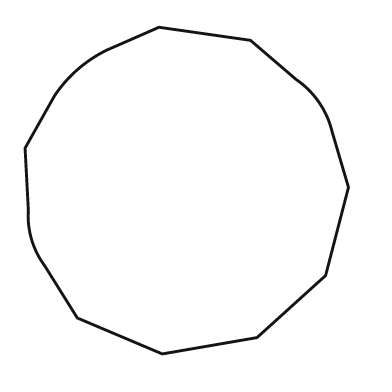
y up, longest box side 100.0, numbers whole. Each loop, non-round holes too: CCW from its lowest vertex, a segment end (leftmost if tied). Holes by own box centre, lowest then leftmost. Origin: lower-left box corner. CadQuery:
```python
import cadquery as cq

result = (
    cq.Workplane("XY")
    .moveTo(42.0, 0.0)
    .lineTo(71.0, 5.0)
    .lineTo(92.0, 24.0)
    .lineTo(99.0, 51.0)
    .lineTo(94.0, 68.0)
    .threePointArc((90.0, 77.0), (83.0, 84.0))
    .lineTo(69.0, 96.0)
    .lineTo(41.0, 100.0)
    .lineTo(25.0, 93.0)
    .threePointArc((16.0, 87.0), (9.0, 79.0))
    .lineTo(0.0, 63.0)
    .lineTo(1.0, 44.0)
    .threePointArc((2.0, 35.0), (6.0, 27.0))
    .lineTo(16.0, 11.0)
    .close()
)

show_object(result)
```